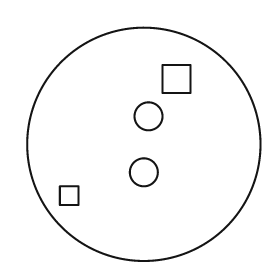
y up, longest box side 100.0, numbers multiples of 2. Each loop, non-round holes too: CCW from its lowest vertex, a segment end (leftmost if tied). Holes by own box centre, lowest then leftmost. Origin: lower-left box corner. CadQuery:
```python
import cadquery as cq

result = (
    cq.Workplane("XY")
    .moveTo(50.0, 50.0)
    .circle(50.0)
    .moveTo(14.0, 24.0)
    .lineTo(22.0, 24.0)
    .lineTo(22.0, 32.0)
    .lineTo(14.0, 32.0)
    .close()
    .moveTo(50.0, 38.0)
    .circle(6.0)
    .moveTo(52.0, 62.0)
    .circle(6.0)
    .moveTo(58.0, 72.0)
    .lineTo(70.0, 72.0)
    .lineTo(70.0, 84.0)
    .lineTo(58.0, 84.0)
    .close()
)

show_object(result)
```